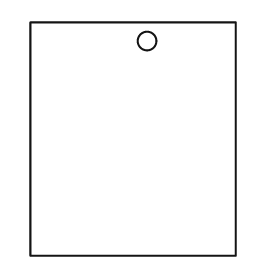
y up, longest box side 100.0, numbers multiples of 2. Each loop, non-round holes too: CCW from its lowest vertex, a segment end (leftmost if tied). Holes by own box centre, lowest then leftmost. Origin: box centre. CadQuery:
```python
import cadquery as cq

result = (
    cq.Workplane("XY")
    .moveTo(-44.0, -50.0)
    .lineTo(44.0, -50.0)
    .lineTo(44.0, 50.0)
    .lineTo(-44.0, 50.0)
    .close()
    .moveTo(6.0, 42.0)
    .circle(4.0)
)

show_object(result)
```